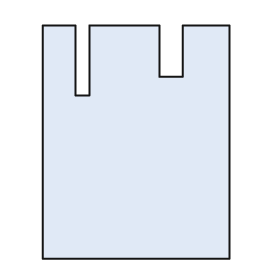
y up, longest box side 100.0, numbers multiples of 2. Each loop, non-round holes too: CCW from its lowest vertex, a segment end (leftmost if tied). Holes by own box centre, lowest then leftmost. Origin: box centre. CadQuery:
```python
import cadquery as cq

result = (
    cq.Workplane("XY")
    .moveTo(-40.0, -50.0)
    .lineTo(40.0, -50.0)
    .lineTo(40.0, 50.0)
    .lineTo(20.0, 50.0)
    .lineTo(20.0, 28.0)
    .lineTo(10.0, 28.0)
    .lineTo(10.0, 50.0)
    .lineTo(-20.0, 50.0)
    .lineTo(-20.0, 20.0)
    .lineTo(-26.0, 20.0)
    .lineTo(-26.0, 50.0)
    .lineTo(-40.0, 50.0)
    .close()
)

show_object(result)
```